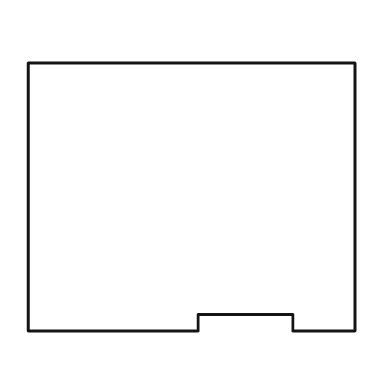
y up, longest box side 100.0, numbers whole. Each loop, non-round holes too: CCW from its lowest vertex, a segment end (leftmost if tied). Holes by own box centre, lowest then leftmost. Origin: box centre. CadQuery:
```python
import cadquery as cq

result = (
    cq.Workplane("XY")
    .moveTo(-50.0, -41.0)
    .lineTo(2.0, -41.0)
    .lineTo(2.0, -36.0)
    .lineTo(31.0, -36.0)
    .lineTo(31.0, -41.0)
    .lineTo(50.0, -41.0)
    .lineTo(50.0, 41.0)
    .lineTo(-50.0, 41.0)
    .close()
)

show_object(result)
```